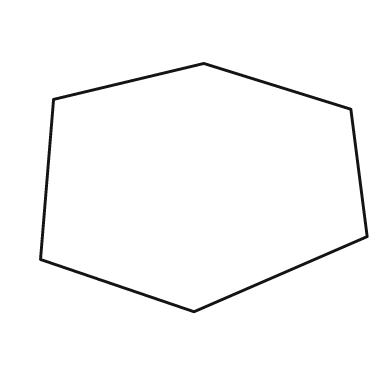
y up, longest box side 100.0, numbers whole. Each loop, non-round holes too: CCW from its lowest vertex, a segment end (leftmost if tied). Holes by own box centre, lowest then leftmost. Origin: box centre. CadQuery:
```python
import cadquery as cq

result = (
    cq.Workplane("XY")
    .moveTo(-3.0, -38.0)
    .lineTo(50.0, -15.0)
    .lineTo(45.0, 24.0)
    .lineTo(0.0, 38.0)
    .lineTo(-46.0, 27.0)
    .lineTo(-50.0, -22.0)
    .close()
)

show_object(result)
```